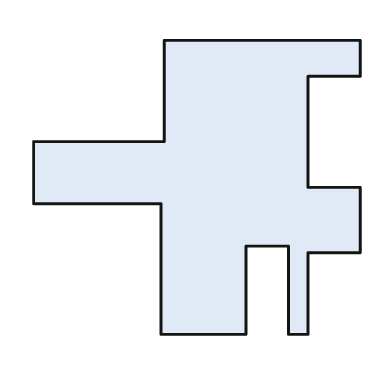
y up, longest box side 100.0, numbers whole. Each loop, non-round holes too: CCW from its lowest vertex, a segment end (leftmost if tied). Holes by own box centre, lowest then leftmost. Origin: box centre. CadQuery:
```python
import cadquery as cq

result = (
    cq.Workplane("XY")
    .moveTo(-11.0, -45.0)
    .lineTo(15.0, -45.0)
    .lineTo(15.0, -18.0)
    .lineTo(28.0, -18.0)
    .lineTo(28.0, -45.0)
    .lineTo(34.0, -45.0)
    .lineTo(34.0, -20.0)
    .lineTo(50.0, -20.0)
    .lineTo(50.0, 0.0)
    .lineTo(34.0, 0.0)
    .lineTo(34.0, 34.0)
    .lineTo(50.0, 34.0)
    .lineTo(50.0, 45.0)
    .lineTo(-10.0, 45.0)
    .lineTo(-10.0, 14.0)
    .lineTo(-50.0, 14.0)
    .lineTo(-50.0, -5.0)
    .lineTo(-11.0, -5.0)
    .close()
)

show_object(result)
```